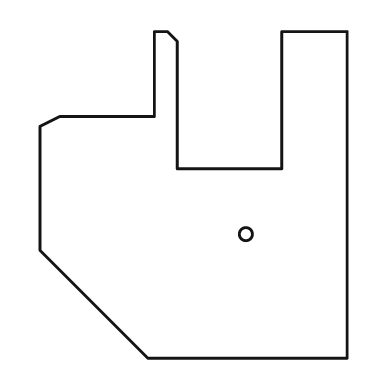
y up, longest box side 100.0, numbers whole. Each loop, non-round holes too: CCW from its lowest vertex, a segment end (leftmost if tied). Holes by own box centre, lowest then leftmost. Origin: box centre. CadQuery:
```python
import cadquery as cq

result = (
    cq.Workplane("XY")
    .moveTo(-14.0, -50.0)
    .lineTo(47.0, -50.0)
    .lineTo(47.0, 50.0)
    .lineTo(27.0, 50.0)
    .lineTo(27.0, 8.0)
    .lineTo(-5.0, 8.0)
    .lineTo(-5.0, 47.0)
    .lineTo(-8.0, 50.0)
    .lineTo(-12.0, 50.0)
    .lineTo(-12.0, 24.0)
    .lineTo(-41.0, 24.0)
    .lineTo(-47.0, 21.0)
    .lineTo(-47.0, -17.0)
    .close()
    .moveTo(16.0, -12.0)
    .circle(2.0)
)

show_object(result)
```